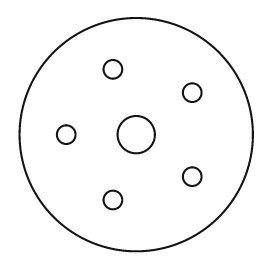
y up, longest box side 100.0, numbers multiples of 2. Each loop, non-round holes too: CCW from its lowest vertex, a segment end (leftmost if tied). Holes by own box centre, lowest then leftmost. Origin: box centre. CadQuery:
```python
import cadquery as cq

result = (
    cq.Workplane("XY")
    .moveTo(0.0, 0.0)
    .circle(50.0)
    .moveTo(-10.0, -28.0)
    .circle(4.0)
    .moveTo(24.0, -18.0)
    .circle(4.0)
    .moveTo(-30.0, 0.0)
    .circle(4.0)
    .moveTo(0.0, 0.0)
    .circle(8.0)
    .moveTo(24.0, 18.0)
    .circle(4.0)
    .moveTo(-10.0, 28.0)
    .circle(4.0)
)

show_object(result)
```